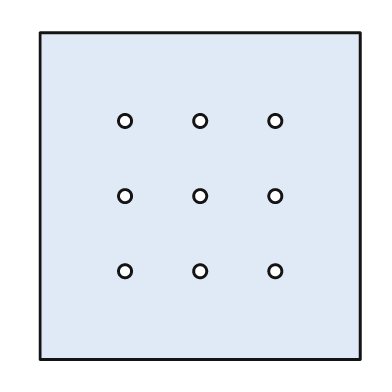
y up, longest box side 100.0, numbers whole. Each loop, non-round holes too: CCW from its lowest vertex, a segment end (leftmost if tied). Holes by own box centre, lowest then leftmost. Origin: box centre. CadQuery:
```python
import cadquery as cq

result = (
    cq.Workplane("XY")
    .moveTo(-49.0, -50.0)
    .lineTo(49.0, -50.0)
    .lineTo(49.0, 50.0)
    .lineTo(-49.0, 50.0)
    .close()
    .moveTo(-23.0, -23.0)
    .circle(2.0)
    .moveTo(0.0, -23.0)
    .circle(2.0)
    .moveTo(23.0, -23.0)
    .circle(2.0)
    .moveTo(-23.0, 0.0)
    .circle(2.0)
    .moveTo(0.0, 0.0)
    .circle(2.0)
    .moveTo(23.0, 0.0)
    .circle(2.0)
    .moveTo(-23.0, 23.0)
    .circle(2.0)
    .moveTo(0.0, 23.0)
    .circle(2.0)
    .moveTo(23.0, 23.0)
    .circle(2.0)
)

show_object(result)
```